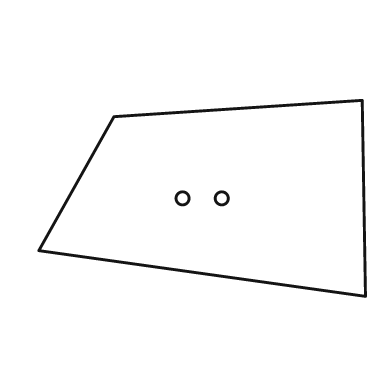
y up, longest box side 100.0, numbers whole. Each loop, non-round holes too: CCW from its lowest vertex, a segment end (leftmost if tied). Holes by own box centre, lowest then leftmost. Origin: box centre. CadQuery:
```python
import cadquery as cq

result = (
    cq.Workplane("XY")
    .moveTo(50.0, -30.0)
    .lineTo(49.0, 30.0)
    .lineTo(-27.0, 25.0)
    .lineTo(-50.0, -16.0)
    .close()
    .moveTo(-6.0, 0.0)
    .circle(2.0)
    .moveTo(6.0, 0.0)
    .circle(2.0)
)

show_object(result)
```